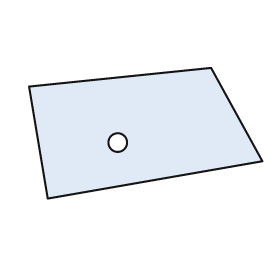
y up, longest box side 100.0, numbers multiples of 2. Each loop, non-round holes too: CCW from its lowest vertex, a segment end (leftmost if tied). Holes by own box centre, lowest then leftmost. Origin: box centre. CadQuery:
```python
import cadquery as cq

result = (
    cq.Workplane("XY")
    .moveTo(-42.0, -28.0)
    .lineTo(50.0, -12.0)
    .lineTo(28.0, 28.0)
    .lineTo(-50.0, 20.0)
    .close()
    .moveTo(-12.0, -4.0)
    .circle(4.0)
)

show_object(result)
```